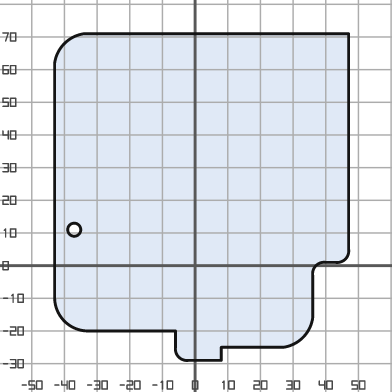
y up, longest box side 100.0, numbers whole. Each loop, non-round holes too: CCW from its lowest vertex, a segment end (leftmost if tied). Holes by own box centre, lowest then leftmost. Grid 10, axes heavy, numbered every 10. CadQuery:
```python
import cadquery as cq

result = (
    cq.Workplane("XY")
    .moveTo(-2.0, -29.0)
    .lineTo(8.0, -29.0)
    .lineTo(8.0, -25.0)
    .lineTo(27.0, -25.0)
    .threePointArc((33.0, -22.0), (36.0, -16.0))
    .lineTo(36.0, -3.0)
    .threePointArc((37.0, 0.0), (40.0, 1.0))
    .lineTo(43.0, 1.0)
    .threePointArc((46.0, 2.0), (47.0, 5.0))
    .lineTo(47.0, 71.0)
    .lineTo(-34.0, 71.0)
    .threePointArc((-40.0, 68.0), (-43.0, 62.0))
    .lineTo(-43.0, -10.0)
    .threePointArc((-40.0, -17.0), (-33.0, -20.0))
    .lineTo(-6.0, -20.0)
    .lineTo(-6.0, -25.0)
    .threePointArc((-5.0, -28.0), (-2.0, -29.0))
    .close()
    .moveTo(-37.0, 11.0)
    .circle(2.0)
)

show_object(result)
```